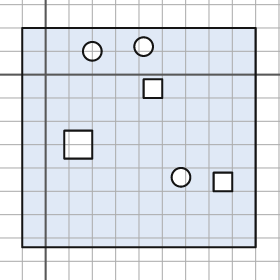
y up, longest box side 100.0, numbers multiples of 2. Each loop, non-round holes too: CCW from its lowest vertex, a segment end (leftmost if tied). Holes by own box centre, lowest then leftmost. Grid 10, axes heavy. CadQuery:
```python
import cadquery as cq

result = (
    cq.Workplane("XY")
    .moveTo(-10.0, -74.0)
    .lineTo(90.0, -74.0)
    .lineTo(90.0, 20.0)
    .lineTo(-10.0, 20.0)
    .close()
    .moveTo(72.0, -50.0)
    .lineTo(80.0, -50.0)
    .lineTo(80.0, -42.0)
    .lineTo(72.0, -42.0)
    .close()
    .moveTo(58.0, -44.0)
    .circle(4.0)
    .moveTo(8.0, -36.0)
    .lineTo(20.0, -36.0)
    .lineTo(20.0, -24.0)
    .lineTo(8.0, -24.0)
    .close()
    .moveTo(42.0, -10.0)
    .lineTo(50.0, -10.0)
    .lineTo(50.0, -2.0)
    .lineTo(42.0, -2.0)
    .close()
    .moveTo(20.0, 10.0)
    .circle(4.0)
    .moveTo(42.0, 12.0)
    .circle(4.0)
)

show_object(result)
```